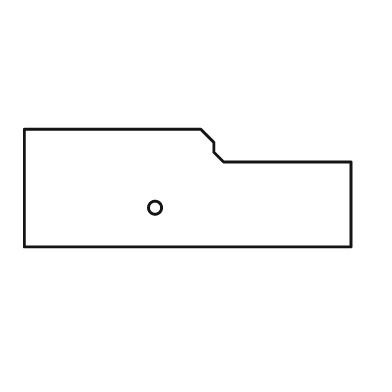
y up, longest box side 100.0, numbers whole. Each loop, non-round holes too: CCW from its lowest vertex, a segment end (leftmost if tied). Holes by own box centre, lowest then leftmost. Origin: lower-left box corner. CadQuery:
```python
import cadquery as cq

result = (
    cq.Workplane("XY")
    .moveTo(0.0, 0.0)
    .lineTo(100.0, 0.0)
    .lineTo(100.0, 26.0)
    .lineTo(61.0, 26.0)
    .lineTo(58.0, 29.0)
    .lineTo(58.0, 32.0)
    .lineTo(54.0, 36.0)
    .lineTo(0.0, 36.0)
    .close()
    .moveTo(40.0, 12.0)
    .circle(2.0)
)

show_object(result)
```